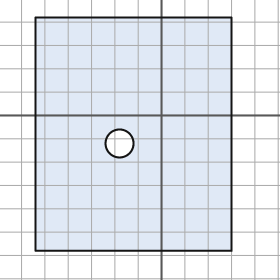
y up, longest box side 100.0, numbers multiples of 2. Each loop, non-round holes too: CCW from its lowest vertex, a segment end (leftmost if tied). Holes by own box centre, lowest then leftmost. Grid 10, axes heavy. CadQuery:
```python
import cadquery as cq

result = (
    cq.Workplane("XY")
    .moveTo(-54.0, -58.0)
    .lineTo(30.0, -58.0)
    .lineTo(30.0, 42.0)
    .lineTo(-54.0, 42.0)
    .close()
    .moveTo(-18.0, -12.0)
    .circle(6.0)
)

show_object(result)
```